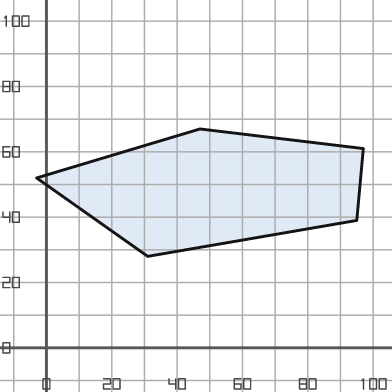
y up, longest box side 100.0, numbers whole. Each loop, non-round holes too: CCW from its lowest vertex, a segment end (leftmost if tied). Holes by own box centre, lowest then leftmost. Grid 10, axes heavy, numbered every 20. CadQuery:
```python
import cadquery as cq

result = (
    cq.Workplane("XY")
    .moveTo(31.0, 28.0)
    .lineTo(95.0, 39.0)
    .lineTo(97.0, 61.0)
    .lineTo(47.0, 67.0)
    .lineTo(-3.0, 52.0)
    .close()
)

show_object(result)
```